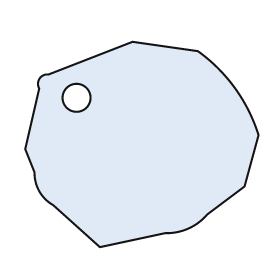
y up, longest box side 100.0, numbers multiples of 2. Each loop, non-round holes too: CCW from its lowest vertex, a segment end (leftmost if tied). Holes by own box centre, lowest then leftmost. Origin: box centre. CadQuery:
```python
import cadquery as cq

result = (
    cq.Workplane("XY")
    .moveTo(-18.0, -44.0)
    .lineTo(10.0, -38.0)
    .threePointArc((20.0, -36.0), (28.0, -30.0))
    .lineTo(44.0, -18.0)
    .lineTo(50.0, 4.0)
    .threePointArc((40.0, 24.0), (24.0, 40.0))
    .lineTo(-4.0, 44.0)
    .lineTo(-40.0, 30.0)
    .threePointArc((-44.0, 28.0), (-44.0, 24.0))
    .lineTo(-50.0, -2.0)
    .lineTo(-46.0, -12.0)
    .threePointArc((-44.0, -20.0), (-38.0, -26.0))
    .close()
    .moveTo(-28.0, 20.0)
    .circle(6.0)
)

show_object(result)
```